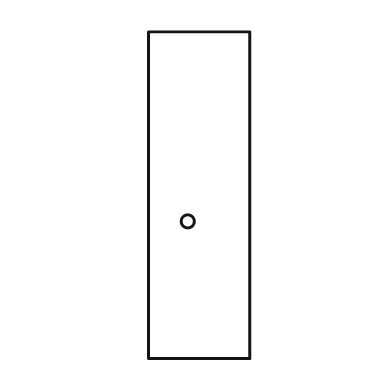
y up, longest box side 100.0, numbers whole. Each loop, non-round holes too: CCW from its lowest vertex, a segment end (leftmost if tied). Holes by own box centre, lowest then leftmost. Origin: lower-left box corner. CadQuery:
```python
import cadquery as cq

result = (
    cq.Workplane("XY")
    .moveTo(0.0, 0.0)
    .lineTo(31.0, 0.0)
    .lineTo(31.0, 100.0)
    .lineTo(0.0, 100.0)
    .close()
    .moveTo(12.0, 42.0)
    .circle(2.0)
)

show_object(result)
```